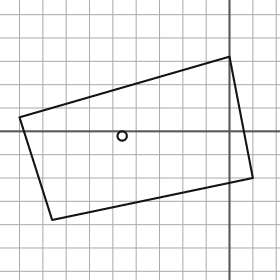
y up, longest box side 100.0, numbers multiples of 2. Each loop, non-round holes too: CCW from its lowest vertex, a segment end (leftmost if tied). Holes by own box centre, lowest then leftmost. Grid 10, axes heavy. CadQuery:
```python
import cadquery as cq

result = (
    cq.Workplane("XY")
    .moveTo(-76.0, -38.0)
    .lineTo(10.0, -20.0)
    .lineTo(0.0, 32.0)
    .lineTo(-90.0, 6.0)
    .close()
    .moveTo(-46.0, -2.0)
    .circle(2.0)
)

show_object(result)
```